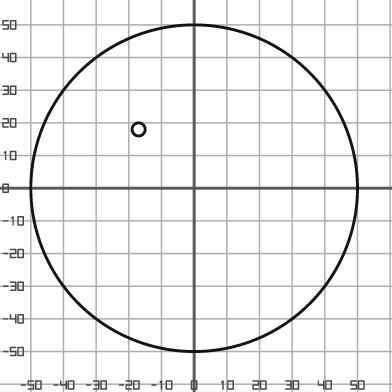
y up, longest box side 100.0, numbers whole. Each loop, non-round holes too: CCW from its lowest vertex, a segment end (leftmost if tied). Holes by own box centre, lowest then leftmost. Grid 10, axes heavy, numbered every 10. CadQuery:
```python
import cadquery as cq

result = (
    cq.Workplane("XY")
    .moveTo(0.0, 0.0)
    .circle(50.0)
    .moveTo(-17.0, 18.0)
    .circle(2.0)
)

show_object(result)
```